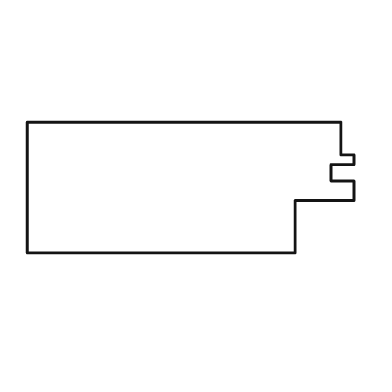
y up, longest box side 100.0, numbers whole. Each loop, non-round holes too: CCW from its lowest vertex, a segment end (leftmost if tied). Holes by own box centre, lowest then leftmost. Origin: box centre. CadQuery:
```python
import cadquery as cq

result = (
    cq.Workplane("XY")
    .moveTo(-50.0, -20.0)
    .lineTo(32.0, -20.0)
    .lineTo(32.0, -4.0)
    .lineTo(50.0, -4.0)
    .lineTo(50.0, 2.0)
    .lineTo(43.0, 2.0)
    .lineTo(43.0, 7.0)
    .lineTo(50.0, 7.0)
    .lineTo(50.0, 10.0)
    .lineTo(46.0, 10.0)
    .lineTo(46.0, 20.0)
    .lineTo(-50.0, 20.0)
    .close()
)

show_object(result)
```